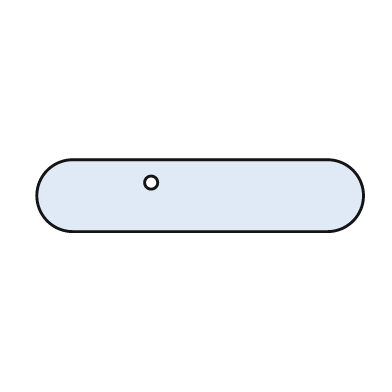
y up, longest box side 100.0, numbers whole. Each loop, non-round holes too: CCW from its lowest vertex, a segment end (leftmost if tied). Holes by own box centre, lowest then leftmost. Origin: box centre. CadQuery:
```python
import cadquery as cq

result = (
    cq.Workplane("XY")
    .moveTo(-39.0, -11.0)
    .lineTo(39.0, -11.0)
    .threePointArc((50.0, 0.0), (39.0, 11.0))
    .lineTo(-39.0, 11.0)
    .threePointArc((-50.0, 0.0), (-39.0, -11.0))
    .close()
    .moveTo(-15.0, 4.0)
    .circle(2.0)
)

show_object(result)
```